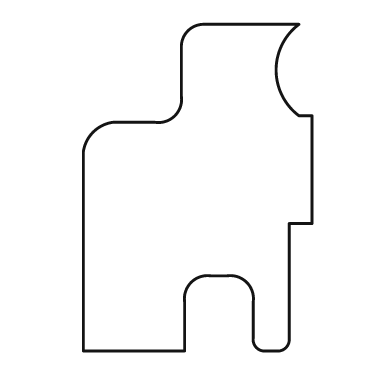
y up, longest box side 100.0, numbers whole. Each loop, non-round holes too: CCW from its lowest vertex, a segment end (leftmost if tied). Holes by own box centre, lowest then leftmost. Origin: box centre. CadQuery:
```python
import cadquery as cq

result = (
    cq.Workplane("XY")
    .moveTo(-35.0, -50.0)
    .lineTo(-4.0, -50.0)
    .lineTo(-4.0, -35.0)
    .threePointArc((-2.0, -29.0), (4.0, -27.0))
    .lineTo(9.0, -27.0)
    .threePointArc((15.0, -29.0), (17.0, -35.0))
    .lineTo(17.0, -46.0)
    .threePointArc((18.0, -49.0), (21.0, -50.0))
    .lineTo(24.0, -50.0)
    .threePointArc((27.0, -49.0), (28.0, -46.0))
    .lineTo(28.0, -11.0)
    .lineTo(35.0, -11.0)
    .lineTo(35.0, 22.0)
    .lineTo(31.0, 22.0)
    .threePointArc((24.0, 36.0), (31.0, 50.0))
    .lineTo(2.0, 50.0)
    .threePointArc((-3.0, 48.0), (-5.0, 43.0))
    .lineTo(-5.0, 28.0)
    .threePointArc((-7.0, 22.0), (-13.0, 20.0))
    .lineTo(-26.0, 20.0)
    .threePointArc((-32.0, 17.0), (-35.0, 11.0))
    .close()
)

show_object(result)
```